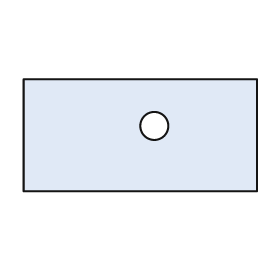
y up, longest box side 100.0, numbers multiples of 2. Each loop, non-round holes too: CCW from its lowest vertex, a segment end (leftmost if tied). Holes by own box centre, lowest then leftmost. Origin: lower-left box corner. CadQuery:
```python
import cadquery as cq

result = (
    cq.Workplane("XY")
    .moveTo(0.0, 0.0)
    .lineTo(100.0, 0.0)
    .lineTo(100.0, 48.0)
    .lineTo(0.0, 48.0)
    .close()
    .moveTo(56.0, 28.0)
    .circle(6.0)
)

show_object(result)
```